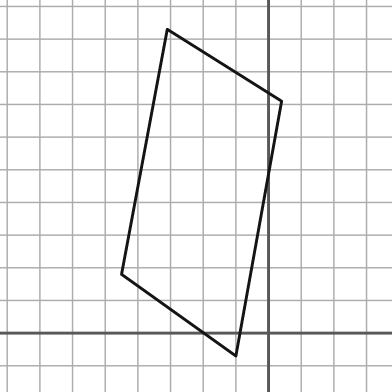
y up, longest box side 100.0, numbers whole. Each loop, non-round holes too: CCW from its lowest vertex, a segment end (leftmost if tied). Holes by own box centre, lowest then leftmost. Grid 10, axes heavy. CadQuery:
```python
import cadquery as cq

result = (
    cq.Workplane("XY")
    .moveTo(-10.0, -7.0)
    .lineTo(4.0, 71.0)
    .lineTo(-31.0, 93.0)
    .lineTo(-45.0, 18.0)
    .close()
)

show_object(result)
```